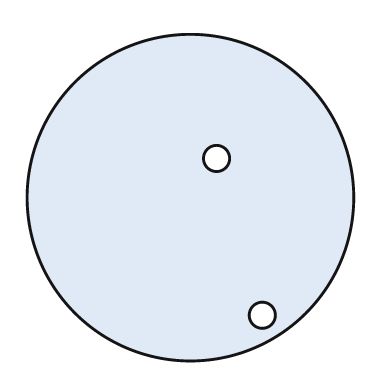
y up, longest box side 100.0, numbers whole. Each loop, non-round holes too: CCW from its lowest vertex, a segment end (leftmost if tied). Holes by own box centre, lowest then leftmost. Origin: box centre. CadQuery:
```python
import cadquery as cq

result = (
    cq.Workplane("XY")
    .moveTo(0.0, 0.0)
    .circle(50.0)
    .moveTo(22.0, -36.0)
    .circle(4.0)
    .moveTo(8.0, 12.0)
    .circle(4.0)
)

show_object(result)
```